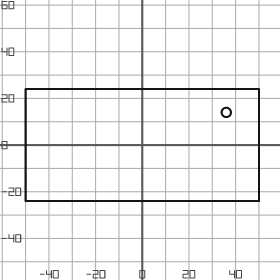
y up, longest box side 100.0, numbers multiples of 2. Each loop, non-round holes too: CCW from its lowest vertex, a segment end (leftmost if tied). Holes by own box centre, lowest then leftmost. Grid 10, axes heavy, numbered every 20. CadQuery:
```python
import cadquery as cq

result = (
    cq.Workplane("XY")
    .moveTo(-50.0, -24.0)
    .lineTo(50.0, -24.0)
    .lineTo(50.0, 24.0)
    .lineTo(-50.0, 24.0)
    .close()
    .moveTo(36.0, 14.0)
    .circle(2.0)
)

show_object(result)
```